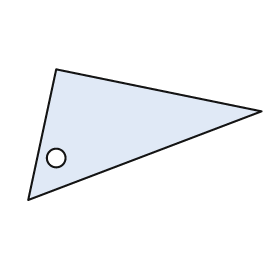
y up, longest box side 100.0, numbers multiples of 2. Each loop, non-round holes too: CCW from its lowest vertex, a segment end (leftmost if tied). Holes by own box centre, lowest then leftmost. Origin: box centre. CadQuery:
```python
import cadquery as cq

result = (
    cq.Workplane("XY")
    .moveTo(-50.0, -28.0)
    .lineTo(50.0, 10.0)
    .lineTo(-38.0, 28.0)
    .close()
    .moveTo(-38.0, -10.0)
    .circle(4.0)
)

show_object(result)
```